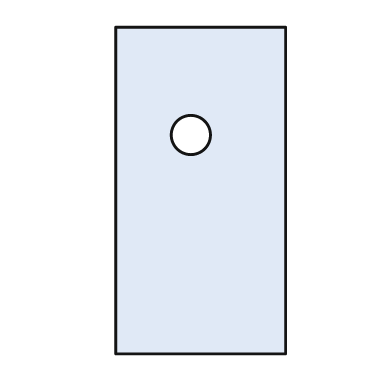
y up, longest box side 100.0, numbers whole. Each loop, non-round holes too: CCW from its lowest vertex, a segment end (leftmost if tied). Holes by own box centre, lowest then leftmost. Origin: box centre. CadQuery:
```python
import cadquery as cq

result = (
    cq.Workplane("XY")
    .moveTo(-26.0, -50.0)
    .lineTo(26.0, -50.0)
    .lineTo(26.0, 50.0)
    .lineTo(-26.0, 50.0)
    .close()
    .moveTo(-3.0, 17.0)
    .circle(6.0)
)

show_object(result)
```